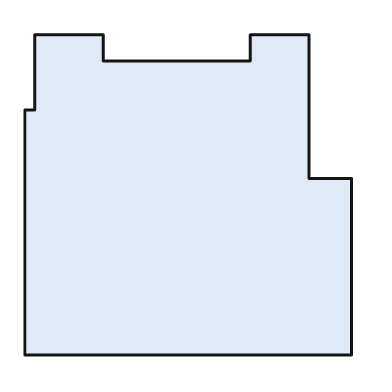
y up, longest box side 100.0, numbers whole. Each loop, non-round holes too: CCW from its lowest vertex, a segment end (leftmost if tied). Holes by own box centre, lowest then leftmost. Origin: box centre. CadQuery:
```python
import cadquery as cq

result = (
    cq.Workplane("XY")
    .moveTo(-50.0, -49.0)
    .lineTo(50.0, -49.0)
    .lineTo(50.0, 5.0)
    .lineTo(37.0, 5.0)
    .lineTo(37.0, 49.0)
    .lineTo(19.0, 49.0)
    .lineTo(19.0, 41.0)
    .lineTo(-26.0, 41.0)
    .lineTo(-26.0, 49.0)
    .lineTo(-47.0, 49.0)
    .lineTo(-47.0, 26.0)
    .lineTo(-50.0, 26.0)
    .close()
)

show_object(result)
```